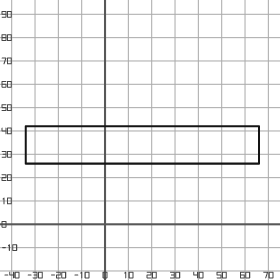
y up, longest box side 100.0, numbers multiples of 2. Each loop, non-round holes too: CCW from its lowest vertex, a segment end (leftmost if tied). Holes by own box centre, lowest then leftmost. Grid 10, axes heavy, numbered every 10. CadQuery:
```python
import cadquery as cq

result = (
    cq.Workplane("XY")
    .moveTo(-34.0, 26.0)
    .lineTo(66.0, 26.0)
    .lineTo(66.0, 42.0)
    .lineTo(-34.0, 42.0)
    .close()
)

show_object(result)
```